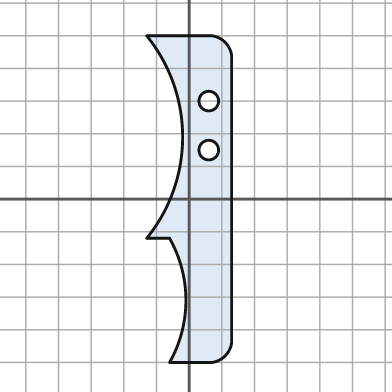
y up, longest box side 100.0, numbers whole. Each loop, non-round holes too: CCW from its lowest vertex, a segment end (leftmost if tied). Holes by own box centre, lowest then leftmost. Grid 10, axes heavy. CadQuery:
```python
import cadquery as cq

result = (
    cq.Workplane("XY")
    .moveTo(-6.0, -50.0)
    .lineTo(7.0, -50.0)
    .threePointArc((11.0, -48.0), (13.0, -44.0))
    .lineTo(13.0, 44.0)
    .threePointArc((11.0, 48.0), (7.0, 50.0))
    .lineTo(-13.0, 50.0)
    .threePointArc((-2.0, 19.0), (-13.0, -12.0))
    .lineTo(-6.0, -12.0)
    .threePointArc((-1.0, -31.0), (-6.0, -50.0))
    .close()
    .moveTo(6.0, 15.0)
    .circle(3.0)
    .moveTo(6.0, 30.0)
    .circle(3.0)
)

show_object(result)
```